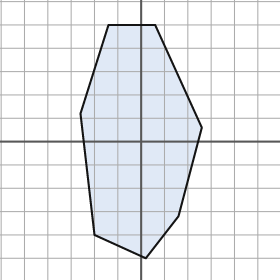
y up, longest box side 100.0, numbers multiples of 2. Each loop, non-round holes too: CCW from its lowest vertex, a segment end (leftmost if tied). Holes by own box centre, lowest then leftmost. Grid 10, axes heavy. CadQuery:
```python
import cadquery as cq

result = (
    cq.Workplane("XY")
    .moveTo(2.0, -50.0)
    .lineTo(16.0, -32.0)
    .lineTo(26.0, 6.0)
    .lineTo(6.0, 50.0)
    .lineTo(-14.0, 50.0)
    .lineTo(-26.0, 12.0)
    .lineTo(-20.0, -40.0)
    .close()
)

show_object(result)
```